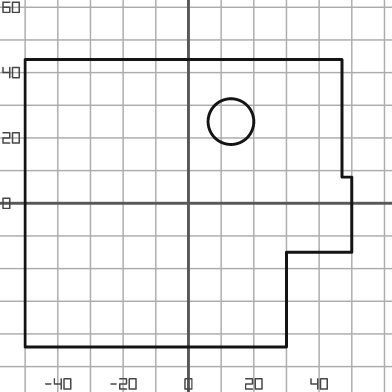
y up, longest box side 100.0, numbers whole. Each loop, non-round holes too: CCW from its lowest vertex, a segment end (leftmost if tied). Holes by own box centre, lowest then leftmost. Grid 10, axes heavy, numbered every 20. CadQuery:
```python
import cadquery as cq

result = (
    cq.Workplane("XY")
    .moveTo(-50.0, -44.0)
    .lineTo(30.0, -44.0)
    .lineTo(30.0, -15.0)
    .lineTo(50.0, -15.0)
    .lineTo(50.0, 8.0)
    .lineTo(47.0, 8.0)
    .lineTo(47.0, 44.0)
    .lineTo(-50.0, 44.0)
    .close()
    .moveTo(13.0, 25.0)
    .circle(7.0)
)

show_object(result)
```